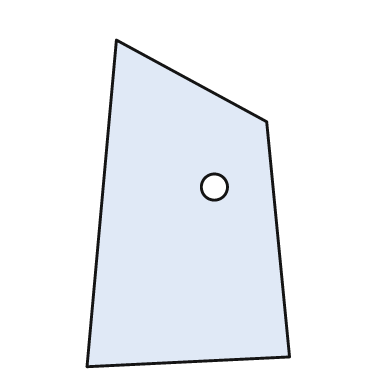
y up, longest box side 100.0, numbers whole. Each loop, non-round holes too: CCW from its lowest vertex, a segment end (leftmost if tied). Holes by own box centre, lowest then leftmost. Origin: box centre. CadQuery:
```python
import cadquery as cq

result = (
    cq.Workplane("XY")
    .moveTo(-31.0, -50.0)
    .lineTo(31.0, -47.0)
    .lineTo(24.0, 25.0)
    .lineTo(-22.0, 50.0)
    .close()
    .moveTo(8.0, 5.0)
    .circle(4.0)
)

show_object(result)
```